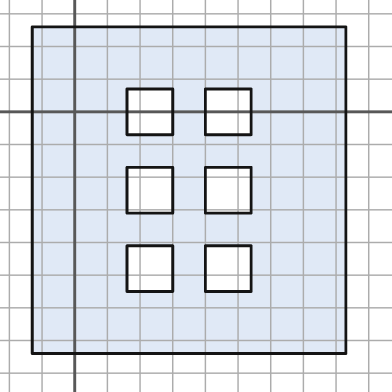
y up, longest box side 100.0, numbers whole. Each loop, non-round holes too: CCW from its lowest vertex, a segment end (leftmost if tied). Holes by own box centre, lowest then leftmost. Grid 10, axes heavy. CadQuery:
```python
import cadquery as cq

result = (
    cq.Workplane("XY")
    .moveTo(-13.0, -74.0)
    .lineTo(83.0, -74.0)
    .lineTo(83.0, 26.0)
    .lineTo(-13.0, 26.0)
    .close()
    .moveTo(16.0, -55.0)
    .lineTo(30.0, -55.0)
    .lineTo(30.0, -41.0)
    .lineTo(16.0, -41.0)
    .close()
    .moveTo(40.0, -55.0)
    .lineTo(54.0, -55.0)
    .lineTo(54.0, -41.0)
    .lineTo(40.0, -41.0)
    .close()
    .moveTo(16.0, -31.0)
    .lineTo(30.0, -31.0)
    .lineTo(30.0, -17.0)
    .lineTo(16.0, -17.0)
    .close()
    .moveTo(40.0, -31.0)
    .lineTo(54.0, -31.0)
    .lineTo(54.0, -17.0)
    .lineTo(40.0, -17.0)
    .close()
    .moveTo(16.0, -7.0)
    .lineTo(30.0, -7.0)
    .lineTo(30.0, 7.0)
    .lineTo(16.0, 7.0)
    .close()
    .moveTo(40.0, -7.0)
    .lineTo(54.0, -7.0)
    .lineTo(54.0, 7.0)
    .lineTo(40.0, 7.0)
    .close()
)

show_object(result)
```